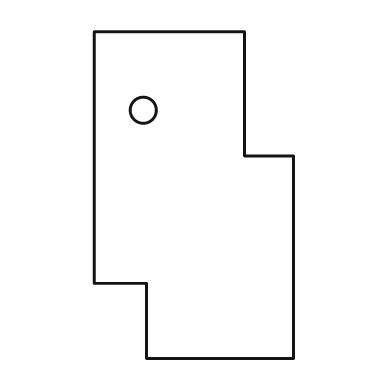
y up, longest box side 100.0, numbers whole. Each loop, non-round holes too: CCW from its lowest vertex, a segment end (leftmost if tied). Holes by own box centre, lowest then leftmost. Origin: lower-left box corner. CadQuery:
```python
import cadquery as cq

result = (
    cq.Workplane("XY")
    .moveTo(16.0, 0.0)
    .lineTo(61.0, 0.0)
    .lineTo(61.0, 62.0)
    .lineTo(46.0, 62.0)
    .lineTo(46.0, 100.0)
    .lineTo(0.0, 100.0)
    .lineTo(0.0, 23.0)
    .lineTo(16.0, 23.0)
    .close()
    .moveTo(15.0, 76.0)
    .circle(4.0)
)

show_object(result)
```